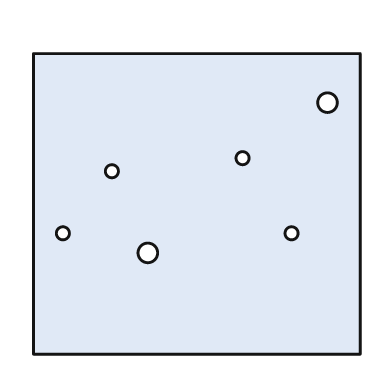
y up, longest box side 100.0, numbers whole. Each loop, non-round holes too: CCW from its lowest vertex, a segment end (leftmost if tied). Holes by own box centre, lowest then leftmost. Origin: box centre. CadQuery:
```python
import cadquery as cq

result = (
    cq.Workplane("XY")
    .moveTo(-50.0, -46.0)
    .lineTo(50.0, -46.0)
    .lineTo(50.0, 46.0)
    .lineTo(-50.0, 46.0)
    .close()
    .moveTo(-15.0, -15.0)
    .circle(3.0)
    .moveTo(-41.0, -9.0)
    .circle(2.0)
    .moveTo(29.0, -9.0)
    .circle(2.0)
    .moveTo(-26.0, 10.0)
    .circle(2.0)
    .moveTo(14.0, 14.0)
    .circle(2.0)
    .moveTo(40.0, 31.0)
    .circle(3.0)
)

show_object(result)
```